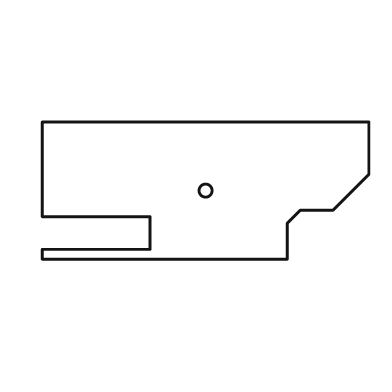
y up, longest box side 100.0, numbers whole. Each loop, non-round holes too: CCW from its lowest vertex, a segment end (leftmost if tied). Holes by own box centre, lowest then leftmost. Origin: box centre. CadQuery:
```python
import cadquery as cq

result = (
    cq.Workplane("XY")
    .moveTo(-50.0, -21.0)
    .lineTo(25.0, -21.0)
    .lineTo(25.0, -10.0)
    .lineTo(29.0, -6.0)
    .lineTo(39.0, -6.0)
    .lineTo(50.0, 5.0)
    .lineTo(50.0, 21.0)
    .lineTo(-50.0, 21.0)
    .lineTo(-50.0, -8.0)
    .lineTo(-17.0, -8.0)
    .lineTo(-17.0, -18.0)
    .lineTo(-50.0, -18.0)
    .close()
    .moveTo(0.0, 0.0)
    .circle(2.0)
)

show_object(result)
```